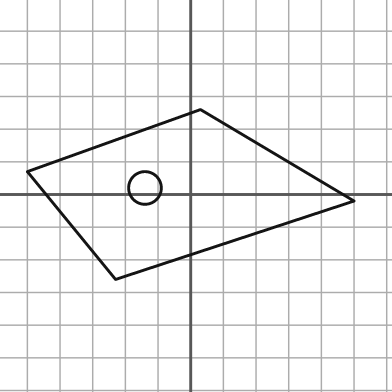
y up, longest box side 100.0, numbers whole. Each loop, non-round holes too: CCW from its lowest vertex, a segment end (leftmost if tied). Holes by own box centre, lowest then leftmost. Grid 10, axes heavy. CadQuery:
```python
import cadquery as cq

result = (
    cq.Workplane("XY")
    .moveTo(-23.0, -26.0)
    .lineTo(50.0, -2.0)
    .lineTo(3.0, 26.0)
    .lineTo(-50.0, 7.0)
    .close()
    .moveTo(-14.0, 2.0)
    .circle(5.0)
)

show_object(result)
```